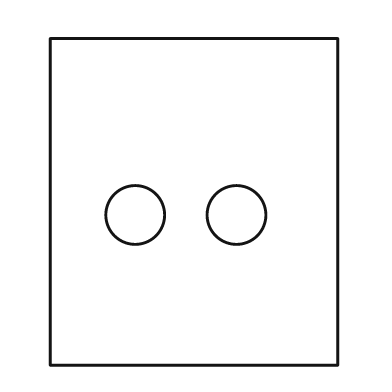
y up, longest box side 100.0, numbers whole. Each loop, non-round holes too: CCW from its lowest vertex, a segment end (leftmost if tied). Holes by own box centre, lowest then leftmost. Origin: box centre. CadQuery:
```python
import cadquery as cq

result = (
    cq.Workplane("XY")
    .moveTo(-44.0, -50.0)
    .lineTo(44.0, -50.0)
    .lineTo(44.0, 50.0)
    .lineTo(-44.0, 50.0)
    .close()
    .moveTo(-18.0, -4.0)
    .circle(9.0)
    .moveTo(13.0, -4.0)
    .circle(9.0)
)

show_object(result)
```